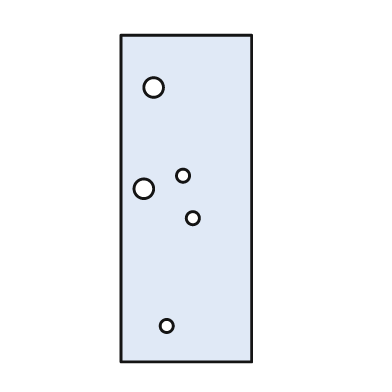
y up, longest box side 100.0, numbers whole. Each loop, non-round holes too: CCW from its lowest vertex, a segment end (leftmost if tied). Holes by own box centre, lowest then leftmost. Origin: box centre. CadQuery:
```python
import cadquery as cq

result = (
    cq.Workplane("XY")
    .moveTo(-20.0, -50.0)
    .lineTo(20.0, -50.0)
    .lineTo(20.0, 50.0)
    .lineTo(-20.0, 50.0)
    .close()
    .moveTo(-6.0, -39.0)
    .circle(2.0)
    .moveTo(2.0, -6.0)
    .circle(2.0)
    .moveTo(-13.0, 3.0)
    .circle(3.0)
    .moveTo(-1.0, 7.0)
    .circle(2.0)
    .moveTo(-10.0, 34.0)
    .circle(3.0)
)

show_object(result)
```